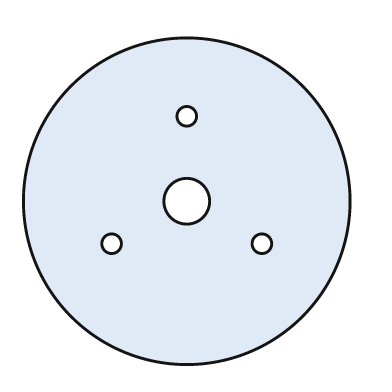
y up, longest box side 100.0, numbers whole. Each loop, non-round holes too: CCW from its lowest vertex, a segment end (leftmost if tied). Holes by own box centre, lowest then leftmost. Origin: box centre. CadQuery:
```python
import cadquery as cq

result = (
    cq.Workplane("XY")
    .moveTo(0.0, 0.0)
    .circle(50.0)
    .moveTo(-23.0, -13.0)
    .circle(3.0)
    .moveTo(23.0, -13.0)
    .circle(3.0)
    .moveTo(0.0, 0.0)
    .circle(7.0)
    .moveTo(0.0, 26.0)
    .circle(3.0)
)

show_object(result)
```